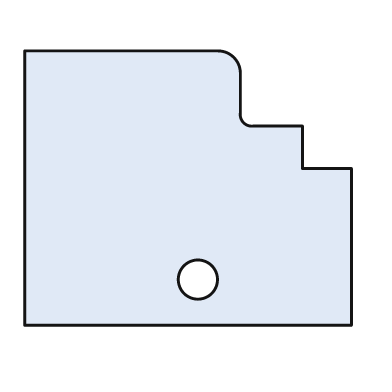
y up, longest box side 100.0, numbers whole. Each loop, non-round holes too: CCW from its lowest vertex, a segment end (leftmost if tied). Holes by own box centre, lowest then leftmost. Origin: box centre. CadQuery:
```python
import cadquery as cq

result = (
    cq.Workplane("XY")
    .moveTo(-50.0, -42.0)
    .lineTo(50.0, -42.0)
    .lineTo(50.0, 6.0)
    .lineTo(35.0, 6.0)
    .lineTo(35.0, 19.0)
    .lineTo(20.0, 19.0)
    .threePointArc((17.0, 20.0), (16.0, 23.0))
    .lineTo(16.0, 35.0)
    .threePointArc((14.0, 40.0), (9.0, 42.0))
    .lineTo(-50.0, 42.0)
    .close()
    .moveTo(3.0, -28.0)
    .circle(6.0)
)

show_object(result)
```